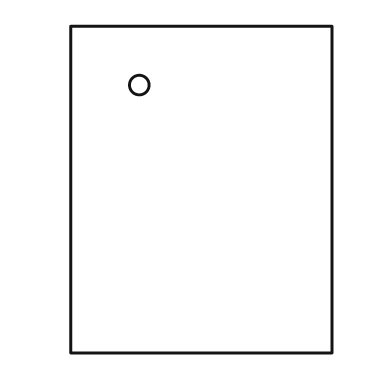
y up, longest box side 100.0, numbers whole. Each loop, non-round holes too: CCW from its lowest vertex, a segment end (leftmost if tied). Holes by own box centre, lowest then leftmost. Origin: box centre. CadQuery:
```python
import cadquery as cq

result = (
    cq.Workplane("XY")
    .moveTo(-40.0, -50.0)
    .lineTo(40.0, -50.0)
    .lineTo(40.0, 50.0)
    .lineTo(-40.0, 50.0)
    .close()
    .moveTo(-19.0, 32.0)
    .circle(3.0)
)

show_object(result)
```